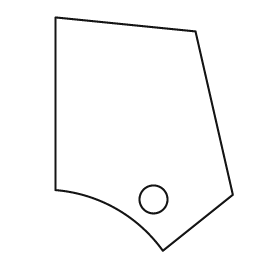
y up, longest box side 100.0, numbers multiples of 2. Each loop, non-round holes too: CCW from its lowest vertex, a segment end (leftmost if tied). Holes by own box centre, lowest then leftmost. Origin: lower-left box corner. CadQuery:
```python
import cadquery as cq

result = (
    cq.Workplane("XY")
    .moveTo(46.0, 0.0)
    .lineTo(76.0, 24.0)
    .lineTo(60.0, 94.0)
    .lineTo(0.0, 100.0)
    .lineTo(0.0, 26.0)
    .threePointArc((26.0, 18.0), (46.0, 0.0))
    .close()
    .moveTo(42.0, 22.0)
    .circle(6.0)
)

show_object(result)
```